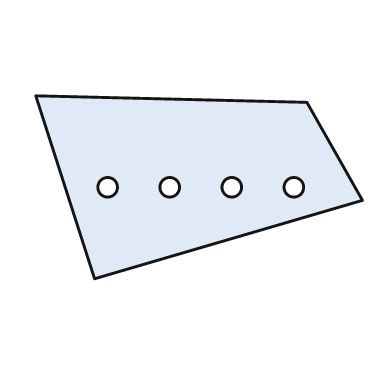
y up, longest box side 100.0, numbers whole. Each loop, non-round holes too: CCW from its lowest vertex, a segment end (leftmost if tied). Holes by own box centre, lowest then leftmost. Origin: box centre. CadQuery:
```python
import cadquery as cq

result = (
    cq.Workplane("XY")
    .moveTo(-32.0, -28.0)
    .lineTo(50.0, -4.0)
    .lineTo(33.0, 26.0)
    .lineTo(-50.0, 28.0)
    .close()
    .moveTo(-28.0, 0.0)
    .circle(3.0)
    .moveTo(-9.0, 0.0)
    .circle(3.0)
    .moveTo(10.0, 0.0)
    .circle(3.0)
    .moveTo(29.0, 0.0)
    .circle(3.0)
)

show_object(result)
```